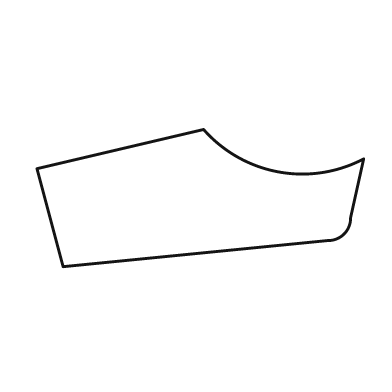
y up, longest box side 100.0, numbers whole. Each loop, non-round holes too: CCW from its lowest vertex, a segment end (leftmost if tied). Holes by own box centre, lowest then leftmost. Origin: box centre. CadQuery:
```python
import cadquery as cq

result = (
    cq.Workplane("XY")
    .moveTo(-42.0, -21.0)
    .lineTo(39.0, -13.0)
    .threePointArc((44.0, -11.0), (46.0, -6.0))
    .lineTo(50.0, 12.0)
    .threePointArc((24.0, 8.0), (1.0, 21.0))
    .lineTo(-50.0, 9.0)
    .close()
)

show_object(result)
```